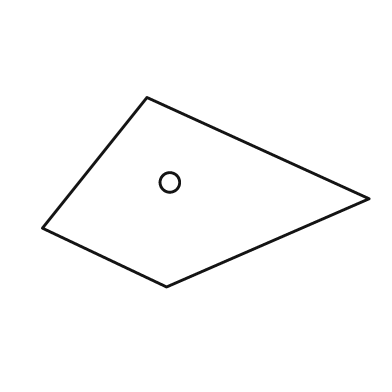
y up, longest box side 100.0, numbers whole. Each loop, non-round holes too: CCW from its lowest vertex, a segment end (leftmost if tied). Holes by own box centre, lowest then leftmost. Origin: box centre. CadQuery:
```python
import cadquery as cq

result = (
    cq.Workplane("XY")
    .moveTo(-12.0, -29.0)
    .lineTo(50.0, -2.0)
    .lineTo(-18.0, 29.0)
    .lineTo(-50.0, -11.0)
    .close()
    .moveTo(-11.0, 3.0)
    .circle(3.0)
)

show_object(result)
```